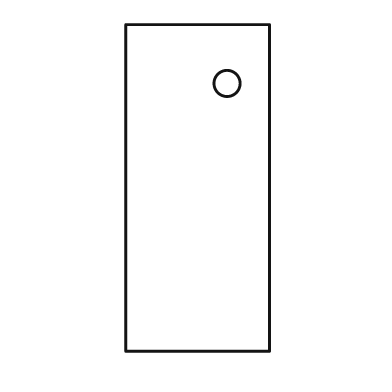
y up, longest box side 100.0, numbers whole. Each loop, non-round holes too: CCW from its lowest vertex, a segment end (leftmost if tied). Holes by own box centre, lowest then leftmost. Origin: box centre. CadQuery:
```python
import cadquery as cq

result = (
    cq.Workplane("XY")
    .moveTo(-22.0, -50.0)
    .lineTo(22.0, -50.0)
    .lineTo(22.0, 50.0)
    .lineTo(-22.0, 50.0)
    .close()
    .moveTo(9.0, 32.0)
    .circle(4.0)
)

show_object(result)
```